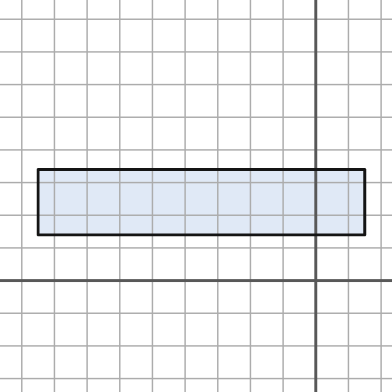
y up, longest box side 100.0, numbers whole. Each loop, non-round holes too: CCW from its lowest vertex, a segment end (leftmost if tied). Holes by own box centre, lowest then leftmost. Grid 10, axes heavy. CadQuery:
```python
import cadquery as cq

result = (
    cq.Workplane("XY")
    .moveTo(-85.0, 14.0)
    .lineTo(15.0, 14.0)
    .lineTo(15.0, 34.0)
    .lineTo(-85.0, 34.0)
    .close()
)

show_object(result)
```